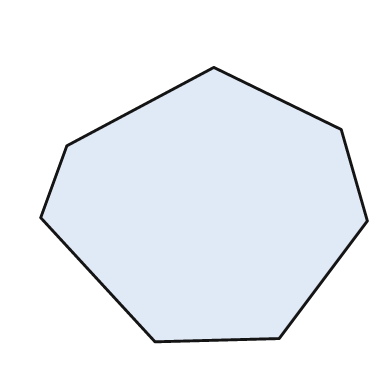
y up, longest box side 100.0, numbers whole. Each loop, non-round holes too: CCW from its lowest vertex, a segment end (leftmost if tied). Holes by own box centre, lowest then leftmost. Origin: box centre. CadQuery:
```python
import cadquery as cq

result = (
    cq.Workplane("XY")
    .moveTo(-15.0, -42.0)
    .lineTo(23.0, -41.0)
    .lineTo(50.0, -5.0)
    .lineTo(42.0, 23.0)
    .lineTo(3.0, 42.0)
    .lineTo(-42.0, 18.0)
    .lineTo(-50.0, -4.0)
    .close()
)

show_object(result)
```